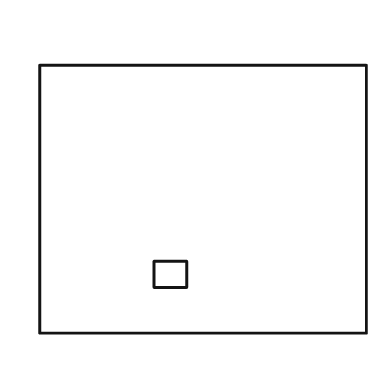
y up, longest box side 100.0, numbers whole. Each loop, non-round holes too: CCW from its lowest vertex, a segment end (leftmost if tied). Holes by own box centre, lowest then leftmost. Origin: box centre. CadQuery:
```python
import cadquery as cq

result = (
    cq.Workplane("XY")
    .moveTo(-50.0, -41.0)
    .lineTo(50.0, -41.0)
    .lineTo(50.0, 41.0)
    .lineTo(-50.0, 41.0)
    .close()
    .moveTo(-15.0, -27.0)
    .lineTo(-5.0, -27.0)
    .lineTo(-5.0, -19.0)
    .lineTo(-15.0, -19.0)
    .close()
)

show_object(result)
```